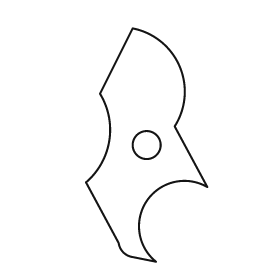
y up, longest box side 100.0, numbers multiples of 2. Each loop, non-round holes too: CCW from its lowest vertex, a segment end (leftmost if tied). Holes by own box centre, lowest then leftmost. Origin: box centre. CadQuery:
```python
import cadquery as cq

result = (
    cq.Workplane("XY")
    .moveTo(4.0, -50.0)
    .threePointArc((0.0, -24.0), (26.0, -18.0))
    .lineTo(12.0, 8.0)
    .threePointArc((14.0, 34.0), (-6.0, 50.0))
    .lineTo(-20.0, 22.0)
    .threePointArc((-16.0, 2.0), (-26.0, -16.0))
    .lineTo(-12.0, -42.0)
    .threePointArc((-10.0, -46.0), (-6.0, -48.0))
    .close()
    .moveTo(0.0, 0.0)
    .circle(6.0)
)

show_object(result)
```